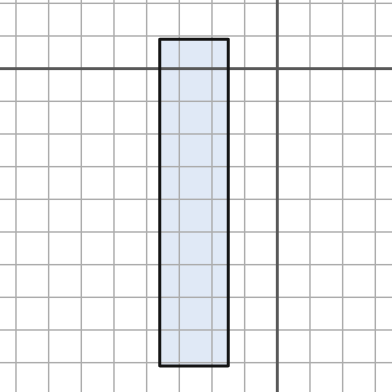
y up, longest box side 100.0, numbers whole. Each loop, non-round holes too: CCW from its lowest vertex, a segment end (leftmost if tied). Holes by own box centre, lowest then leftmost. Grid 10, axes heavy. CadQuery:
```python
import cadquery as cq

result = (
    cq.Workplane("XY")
    .moveTo(-36.0, -91.0)
    .lineTo(-15.0, -91.0)
    .lineTo(-15.0, 9.0)
    .lineTo(-36.0, 9.0)
    .close()
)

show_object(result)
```